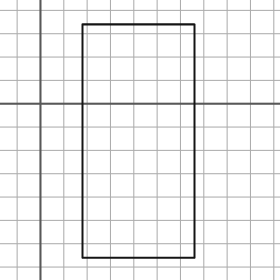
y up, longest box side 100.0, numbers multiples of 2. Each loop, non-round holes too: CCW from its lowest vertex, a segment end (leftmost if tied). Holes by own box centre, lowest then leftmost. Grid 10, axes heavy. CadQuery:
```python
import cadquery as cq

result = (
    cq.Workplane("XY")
    .moveTo(18.0, -66.0)
    .lineTo(66.0, -66.0)
    .lineTo(66.0, 34.0)
    .lineTo(18.0, 34.0)
    .close()
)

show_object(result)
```